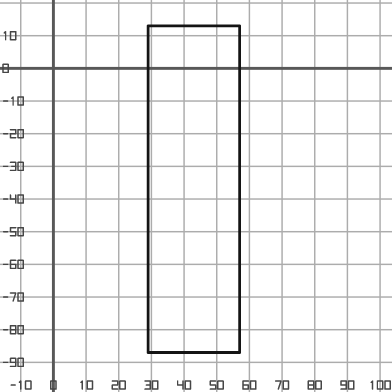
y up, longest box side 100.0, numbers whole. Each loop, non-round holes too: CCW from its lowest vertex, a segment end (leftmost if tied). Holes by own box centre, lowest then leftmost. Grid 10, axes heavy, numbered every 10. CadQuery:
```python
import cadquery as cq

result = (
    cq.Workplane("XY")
    .moveTo(29.0, -87.0)
    .lineTo(57.0, -87.0)
    .lineTo(57.0, 13.0)
    .lineTo(29.0, 13.0)
    .close()
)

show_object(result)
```